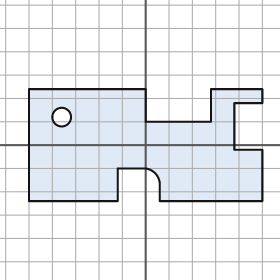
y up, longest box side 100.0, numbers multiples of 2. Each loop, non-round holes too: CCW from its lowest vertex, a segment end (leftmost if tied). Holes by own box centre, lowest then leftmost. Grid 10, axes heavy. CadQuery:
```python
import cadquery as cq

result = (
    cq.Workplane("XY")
    .moveTo(-50.0, -24.0)
    .lineTo(-12.0, -24.0)
    .lineTo(-12.0, -10.0)
    .lineTo(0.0, -10.0)
    .threePointArc((4.0, -12.0), (6.0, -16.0))
    .lineTo(6.0, -24.0)
    .lineTo(50.0, -24.0)
    .lineTo(50.0, -2.0)
    .lineTo(38.0, -2.0)
    .lineTo(38.0, 18.0)
    .lineTo(50.0, 18.0)
    .lineTo(50.0, 24.0)
    .lineTo(28.0, 24.0)
    .lineTo(28.0, 10.0)
    .lineTo(0.0, 10.0)
    .lineTo(0.0, 24.0)
    .lineTo(-50.0, 24.0)
    .close()
    .moveTo(-36.0, 12.0)
    .circle(4.0)
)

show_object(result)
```